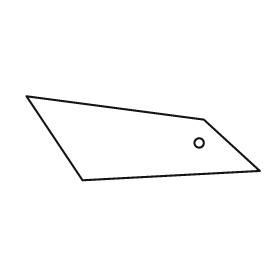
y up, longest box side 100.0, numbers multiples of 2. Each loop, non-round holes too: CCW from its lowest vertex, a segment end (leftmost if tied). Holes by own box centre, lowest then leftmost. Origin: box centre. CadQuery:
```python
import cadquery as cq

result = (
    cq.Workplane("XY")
    .moveTo(-26.0, -18.0)
    .lineTo(50.0, -14.0)
    .lineTo(26.0, 8.0)
    .lineTo(-50.0, 18.0)
    .close()
    .moveTo(24.0, -2.0)
    .circle(2.0)
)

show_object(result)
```